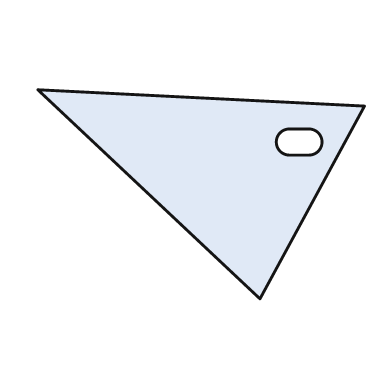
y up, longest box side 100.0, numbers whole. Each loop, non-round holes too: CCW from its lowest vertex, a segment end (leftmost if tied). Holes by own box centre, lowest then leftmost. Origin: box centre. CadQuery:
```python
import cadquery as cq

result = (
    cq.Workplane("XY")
    .moveTo(18.0, -32.0)
    .lineTo(50.0, 27.0)
    .lineTo(-50.0, 32.0)
    .close()
    .moveTo(27.0, 12.0)
    .lineTo(33.0, 12.0)
    .threePointArc((37.0, 16.0), (33.0, 20.0))
    .lineTo(27.0, 20.0)
    .threePointArc((23.0, 16.0), (27.0, 12.0))
    .close()
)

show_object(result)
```